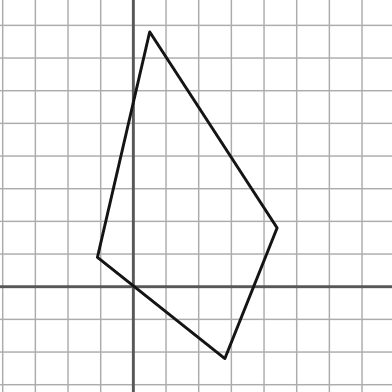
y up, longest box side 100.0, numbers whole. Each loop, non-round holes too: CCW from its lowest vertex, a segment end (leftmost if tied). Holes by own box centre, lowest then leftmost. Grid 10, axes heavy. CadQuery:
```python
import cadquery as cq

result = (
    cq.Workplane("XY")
    .moveTo(28.0, -22.0)
    .lineTo(44.0, 18.0)
    .lineTo(5.0, 78.0)
    .lineTo(-11.0, 9.0)
    .close()
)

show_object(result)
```